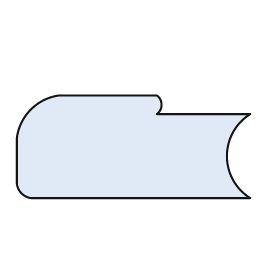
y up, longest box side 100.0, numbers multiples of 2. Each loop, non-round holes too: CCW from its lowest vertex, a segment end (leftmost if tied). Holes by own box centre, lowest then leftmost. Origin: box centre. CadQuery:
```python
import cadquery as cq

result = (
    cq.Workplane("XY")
    .moveTo(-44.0, -22.0)
    .lineTo(50.0, -22.0)
    .threePointArc((40.0, -4.0), (50.0, 14.0))
    .lineTo(10.0, 14.0)
    .threePointArc((12.0, 18.0), (10.0, 22.0))
    .lineTo(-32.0, 22.0)
    .threePointArc((-44.0, 16.0), (-50.0, 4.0))
    .lineTo(-50.0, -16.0)
    .threePointArc((-48.0, -20.0), (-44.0, -22.0))
    .close()
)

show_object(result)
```